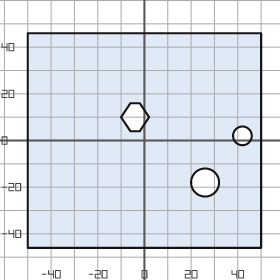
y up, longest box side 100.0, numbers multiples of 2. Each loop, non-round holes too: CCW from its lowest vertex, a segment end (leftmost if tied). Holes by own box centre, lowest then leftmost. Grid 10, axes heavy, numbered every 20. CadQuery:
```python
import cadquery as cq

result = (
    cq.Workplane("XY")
    .moveTo(-50.0, -46.0)
    .lineTo(50.0, -46.0)
    .lineTo(50.0, 46.0)
    .lineTo(-50.0, 46.0)
    .close()
    .moveTo(26.0, -18.0)
    .circle(6.0)
    .moveTo(42.0, 2.0)
    .circle(4.0)
    .moveTo(-6.0, 4.0)
    .lineTo(-2.0, 4.0)
    .lineTo(2.0, 10.0)
    .lineTo(-2.0, 16.0)
    .lineTo(-6.0, 16.0)
    .lineTo(-10.0, 10.0)
    .close()
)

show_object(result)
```